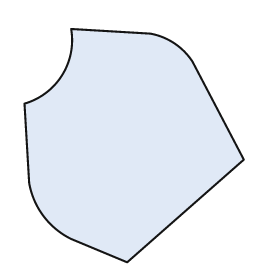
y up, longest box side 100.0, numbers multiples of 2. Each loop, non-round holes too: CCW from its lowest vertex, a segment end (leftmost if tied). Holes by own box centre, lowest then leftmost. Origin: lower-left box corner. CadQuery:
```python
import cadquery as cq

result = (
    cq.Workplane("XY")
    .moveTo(44.0, 0.0)
    .lineTo(94.0, 44.0)
    .lineTo(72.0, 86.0)
    .threePointArc((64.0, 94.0), (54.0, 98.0))
    .lineTo(20.0, 100.0)
    .threePointArc((16.0, 80.0), (0.0, 68.0))
    .lineTo(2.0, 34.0)
    .threePointArc((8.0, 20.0), (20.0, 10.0))
    .close()
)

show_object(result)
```